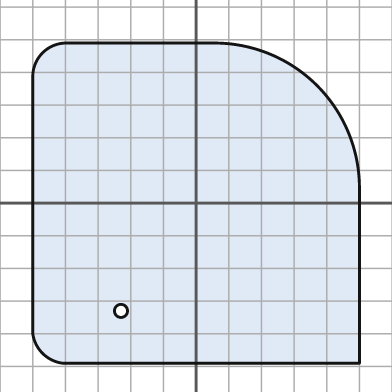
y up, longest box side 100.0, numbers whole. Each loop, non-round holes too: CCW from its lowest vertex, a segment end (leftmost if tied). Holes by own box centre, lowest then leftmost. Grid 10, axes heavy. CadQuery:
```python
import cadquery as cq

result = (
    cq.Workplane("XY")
    .moveTo(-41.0, -49.0)
    .lineTo(50.0, -49.0)
    .lineTo(50.0, 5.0)
    .threePointArc((37.0, 36.0), (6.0, 49.0))
    .lineTo(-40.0, 49.0)
    .threePointArc((-47.0, 46.0), (-50.0, 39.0))
    .lineTo(-50.0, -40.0)
    .threePointArc((-47.0, -46.0), (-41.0, -49.0))
    .close()
    .moveTo(-23.0, -33.0)
    .circle(2.0)
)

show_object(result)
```